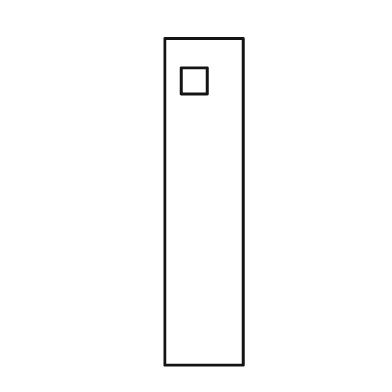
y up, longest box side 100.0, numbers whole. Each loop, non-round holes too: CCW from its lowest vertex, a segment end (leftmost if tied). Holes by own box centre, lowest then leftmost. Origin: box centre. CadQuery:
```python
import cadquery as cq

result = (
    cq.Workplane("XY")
    .moveTo(-12.0, -50.0)
    .lineTo(12.0, -50.0)
    .lineTo(12.0, 50.0)
    .lineTo(-12.0, 50.0)
    .close()
    .moveTo(-7.0, 33.0)
    .lineTo(1.0, 33.0)
    .lineTo(1.0, 41.0)
    .lineTo(-7.0, 41.0)
    .close()
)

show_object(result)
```